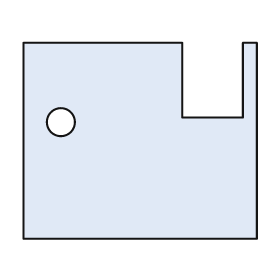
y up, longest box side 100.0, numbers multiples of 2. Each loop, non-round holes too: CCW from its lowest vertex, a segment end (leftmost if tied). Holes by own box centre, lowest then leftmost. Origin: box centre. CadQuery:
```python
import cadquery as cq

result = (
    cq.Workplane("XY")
    .moveTo(-50.0, -42.0)
    .lineTo(50.0, -42.0)
    .lineTo(50.0, 42.0)
    .lineTo(44.0, 42.0)
    .lineTo(44.0, 10.0)
    .lineTo(18.0, 10.0)
    .lineTo(18.0, 42.0)
    .lineTo(-50.0, 42.0)
    .close()
    .moveTo(-34.0, 8.0)
    .circle(6.0)
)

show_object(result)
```